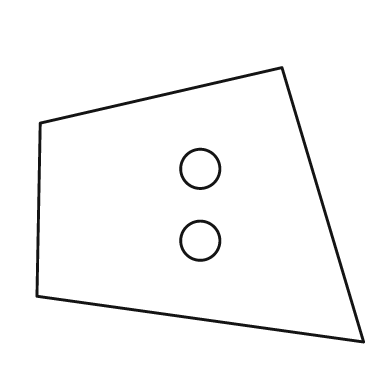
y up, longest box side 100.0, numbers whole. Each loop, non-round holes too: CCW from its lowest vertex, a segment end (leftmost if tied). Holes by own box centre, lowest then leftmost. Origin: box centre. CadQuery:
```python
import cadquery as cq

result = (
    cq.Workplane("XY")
    .moveTo(50.0, -42.0)
    .lineTo(25.0, 42.0)
    .lineTo(-49.0, 25.0)
    .lineTo(-50.0, -28.0)
    .close()
    .moveTo(0.0, -11.0)
    .circle(6.0)
    .moveTo(0.0, 11.0)
    .circle(6.0)
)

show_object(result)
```